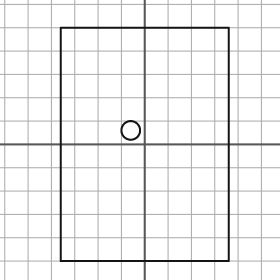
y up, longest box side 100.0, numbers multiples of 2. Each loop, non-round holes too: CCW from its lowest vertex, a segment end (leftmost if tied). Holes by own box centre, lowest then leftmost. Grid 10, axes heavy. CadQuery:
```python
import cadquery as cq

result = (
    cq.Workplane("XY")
    .moveTo(-36.0, -50.0)
    .lineTo(36.0, -50.0)
    .lineTo(36.0, 50.0)
    .lineTo(-36.0, 50.0)
    .close()
    .moveTo(-6.0, 6.0)
    .circle(4.0)
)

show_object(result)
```